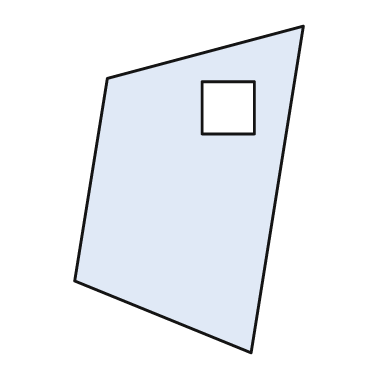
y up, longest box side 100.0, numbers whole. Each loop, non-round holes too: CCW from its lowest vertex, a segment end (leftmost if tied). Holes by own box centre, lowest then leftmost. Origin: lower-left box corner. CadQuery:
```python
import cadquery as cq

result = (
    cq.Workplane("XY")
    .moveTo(54.0, 0.0)
    .lineTo(70.0, 100.0)
    .lineTo(10.0, 84.0)
    .lineTo(0.0, 22.0)
    .close()
    .moveTo(39.0, 67.0)
    .lineTo(55.0, 67.0)
    .lineTo(55.0, 83.0)
    .lineTo(39.0, 83.0)
    .close()
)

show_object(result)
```